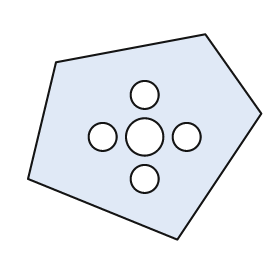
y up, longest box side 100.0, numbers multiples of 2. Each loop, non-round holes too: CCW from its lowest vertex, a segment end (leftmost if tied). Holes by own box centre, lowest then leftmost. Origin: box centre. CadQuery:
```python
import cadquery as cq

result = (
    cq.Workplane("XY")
    .moveTo(14.0, -44.0)
    .lineTo(50.0, 10.0)
    .lineTo(26.0, 44.0)
    .lineTo(-38.0, 32.0)
    .lineTo(-50.0, -18.0)
    .close()
    .moveTo(0.0, -18.0)
    .circle(6.0)
    .moveTo(-18.0, 0.0)
    .circle(6.0)
    .moveTo(0.0, 0.0)
    .circle(8.0)
    .moveTo(18.0, 0.0)
    .circle(6.0)
    .moveTo(0.0, 18.0)
    .circle(6.0)
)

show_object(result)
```